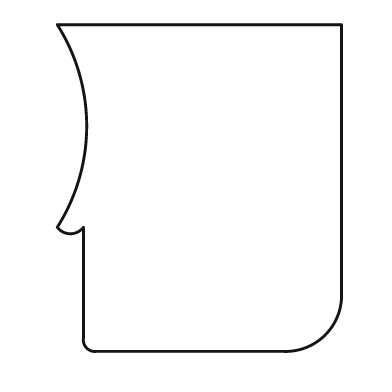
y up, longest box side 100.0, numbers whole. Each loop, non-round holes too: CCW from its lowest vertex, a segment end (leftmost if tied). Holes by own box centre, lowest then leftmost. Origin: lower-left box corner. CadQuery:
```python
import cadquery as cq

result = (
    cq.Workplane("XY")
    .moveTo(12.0, 0.0)
    .lineTo(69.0, 0.0)
    .threePointArc((82.0, 5.0), (87.0, 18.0))
    .lineTo(87.0, 100.0)
    .lineTo(0.0, 100.0)
    .threePointArc((9.0, 69.0), (0.0, 38.0))
    .threePointArc((4.0, 36.0), (8.0, 38.0))
    .lineTo(8.0, 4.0)
    .threePointArc((9.0, 1.0), (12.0, 0.0))
    .close()
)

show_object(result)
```